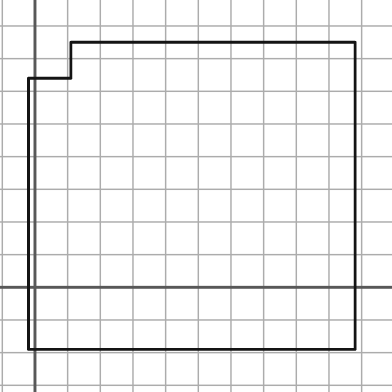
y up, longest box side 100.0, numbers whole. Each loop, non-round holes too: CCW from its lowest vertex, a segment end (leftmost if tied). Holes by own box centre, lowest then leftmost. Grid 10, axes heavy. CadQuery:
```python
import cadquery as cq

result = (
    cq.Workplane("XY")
    .moveTo(-2.0, -19.0)
    .lineTo(98.0, -19.0)
    .lineTo(98.0, 75.0)
    .lineTo(11.0, 75.0)
    .lineTo(11.0, 64.0)
    .lineTo(-2.0, 64.0)
    .close()
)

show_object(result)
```